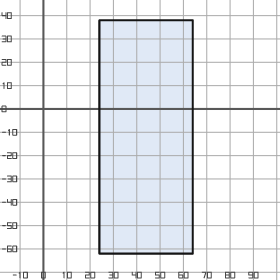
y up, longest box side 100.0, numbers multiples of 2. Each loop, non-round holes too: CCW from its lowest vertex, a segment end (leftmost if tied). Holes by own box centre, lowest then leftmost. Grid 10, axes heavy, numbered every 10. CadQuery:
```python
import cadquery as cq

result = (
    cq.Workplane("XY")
    .moveTo(24.0, -62.0)
    .lineTo(64.0, -62.0)
    .lineTo(64.0, 38.0)
    .lineTo(24.0, 38.0)
    .close()
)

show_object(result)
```